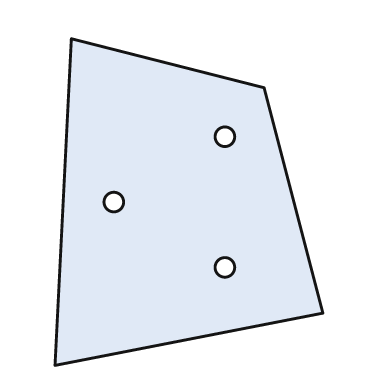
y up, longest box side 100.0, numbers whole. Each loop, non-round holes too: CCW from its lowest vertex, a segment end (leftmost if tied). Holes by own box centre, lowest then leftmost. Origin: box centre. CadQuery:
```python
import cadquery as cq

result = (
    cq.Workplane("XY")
    .moveTo(-41.0, -50.0)
    .lineTo(41.0, -34.0)
    .lineTo(23.0, 35.0)
    .lineTo(-36.0, 50.0)
    .close()
    .moveTo(11.0, -20.0)
    .circle(3.0)
    .moveTo(-23.0, 0.0)
    .circle(3.0)
    .moveTo(11.0, 20.0)
    .circle(3.0)
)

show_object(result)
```